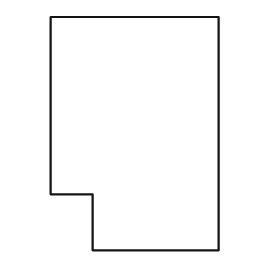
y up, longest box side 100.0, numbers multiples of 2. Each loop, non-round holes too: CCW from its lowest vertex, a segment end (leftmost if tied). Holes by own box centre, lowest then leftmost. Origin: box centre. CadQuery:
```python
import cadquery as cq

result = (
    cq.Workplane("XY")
    .moveTo(-18.0, -50.0)
    .lineTo(36.0, -50.0)
    .lineTo(36.0, 50.0)
    .lineTo(-36.0, 50.0)
    .lineTo(-36.0, -26.0)
    .lineTo(-18.0, -26.0)
    .close()
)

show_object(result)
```